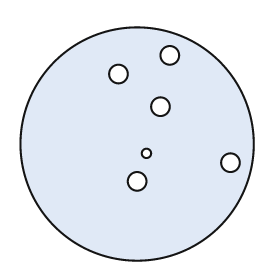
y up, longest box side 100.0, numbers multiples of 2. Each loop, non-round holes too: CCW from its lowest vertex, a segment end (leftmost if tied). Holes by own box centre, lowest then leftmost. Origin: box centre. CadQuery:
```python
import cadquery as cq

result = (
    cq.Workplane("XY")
    .moveTo(0.0, 0.0)
    .circle(50.0)
    .moveTo(0.0, -16.0)
    .circle(4.0)
    .moveTo(40.0, -8.0)
    .circle(4.0)
    .moveTo(4.0, -4.0)
    .circle(2.0)
    .moveTo(10.0, 16.0)
    .circle(4.0)
    .moveTo(-8.0, 30.0)
    .circle(4.0)
    .moveTo(14.0, 38.0)
    .circle(4.0)
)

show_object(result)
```